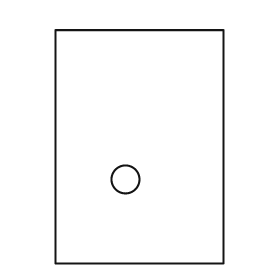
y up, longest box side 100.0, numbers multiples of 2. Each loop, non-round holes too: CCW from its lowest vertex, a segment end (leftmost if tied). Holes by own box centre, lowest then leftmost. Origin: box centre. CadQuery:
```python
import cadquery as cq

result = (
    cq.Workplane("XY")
    .moveTo(-36.0, -50.0)
    .lineTo(36.0, -50.0)
    .lineTo(36.0, 50.0)
    .lineTo(-36.0, 50.0)
    .close()
    .moveTo(-6.0, -14.0)
    .circle(6.0)
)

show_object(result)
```